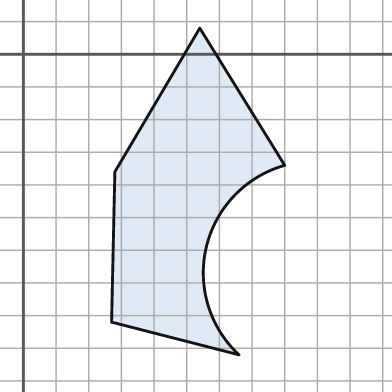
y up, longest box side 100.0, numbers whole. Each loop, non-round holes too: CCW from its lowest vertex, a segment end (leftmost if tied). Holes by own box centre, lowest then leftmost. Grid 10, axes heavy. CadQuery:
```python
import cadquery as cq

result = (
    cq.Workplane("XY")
    .moveTo(66.0, -92.0)
    .threePointArc((56.0, -59.0), (80.0, -34.0))
    .lineTo(54.0, 8.0)
    .lineTo(28.0, -36.0)
    .lineTo(27.0, -82.0)
    .close()
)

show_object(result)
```